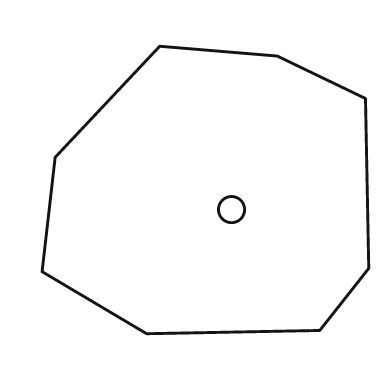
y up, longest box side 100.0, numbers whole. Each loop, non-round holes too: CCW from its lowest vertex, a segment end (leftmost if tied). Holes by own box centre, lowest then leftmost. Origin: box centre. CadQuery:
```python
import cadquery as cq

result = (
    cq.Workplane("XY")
    .moveTo(-18.0, -44.0)
    .lineTo(35.0, -43.0)
    .lineTo(50.0, -24.0)
    .lineTo(49.0, 28.0)
    .lineTo(22.0, 41.0)
    .lineTo(-14.0, 44.0)
    .lineTo(-46.0, 10.0)
    .lineTo(-50.0, -25.0)
    .close()
    .moveTo(8.0, -6.0)
    .circle(4.0)
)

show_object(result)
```